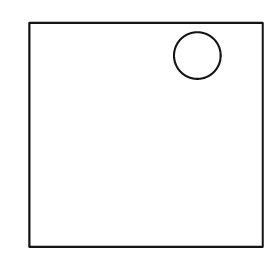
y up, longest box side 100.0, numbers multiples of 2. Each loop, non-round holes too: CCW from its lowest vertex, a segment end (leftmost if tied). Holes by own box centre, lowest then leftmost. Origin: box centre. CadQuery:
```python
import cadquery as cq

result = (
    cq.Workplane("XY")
    .moveTo(-50.0, -48.0)
    .lineTo(50.0, -48.0)
    .lineTo(50.0, 48.0)
    .lineTo(-50.0, 48.0)
    .close()
    .moveTo(22.0, 34.0)
    .circle(10.0)
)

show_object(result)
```